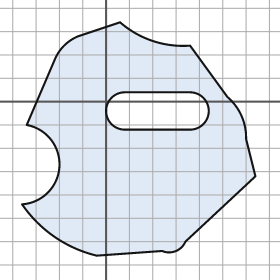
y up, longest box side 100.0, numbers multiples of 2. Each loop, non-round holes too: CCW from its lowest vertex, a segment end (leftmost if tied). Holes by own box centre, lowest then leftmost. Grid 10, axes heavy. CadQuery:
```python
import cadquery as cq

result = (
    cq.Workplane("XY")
    .moveTo(-4.0, -66.0)
    .lineTo(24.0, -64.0)
    .threePointArc((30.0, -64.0), (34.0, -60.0))
    .lineTo(64.0, -32.0)
    .lineTo(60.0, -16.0)
    .threePointArc((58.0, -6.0), (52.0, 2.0))
    .lineTo(36.0, 24.0)
    .threePointArc((20.0, 26.0), (6.0, 34.0))
    .lineTo(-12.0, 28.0)
    .threePointArc((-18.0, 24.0), (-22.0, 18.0))
    .lineTo(-34.0, -10.0)
    .threePointArc((-20.0, -28.0), (-36.0, -44.0))
    .threePointArc((-22.0, -58.0), (-4.0, -66.0))
    .close()
    .moveTo(8.0, -12.0)
    .lineTo(36.0, -12.0)
    .threePointArc((44.0, -4.0), (36.0, 4.0))
    .lineTo(8.0, 4.0)
    .threePointArc((0.0, -4.0), (8.0, -12.0))
    .close()
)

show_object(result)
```